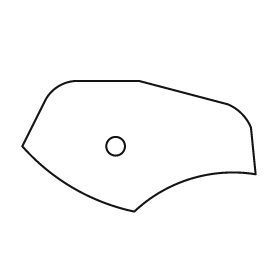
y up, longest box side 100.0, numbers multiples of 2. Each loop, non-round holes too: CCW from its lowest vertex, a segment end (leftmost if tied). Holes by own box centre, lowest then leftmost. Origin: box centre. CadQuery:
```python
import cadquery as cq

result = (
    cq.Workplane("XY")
    .moveTo(-2.0, -28.0)
    .threePointArc((22.0, -14.0), (50.0, -12.0))
    .lineTo(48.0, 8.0)
    .threePointArc((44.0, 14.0), (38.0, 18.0))
    .lineTo(0.0, 28.0)
    .lineTo(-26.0, 28.0)
    .threePointArc((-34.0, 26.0), (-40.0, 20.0))
    .lineTo(-50.0, 0.0)
    .threePointArc((-28.0, -18.0), (-2.0, -28.0))
    .close()
    .moveTo(-10.0, 0.0)
    .circle(4.0)
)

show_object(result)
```